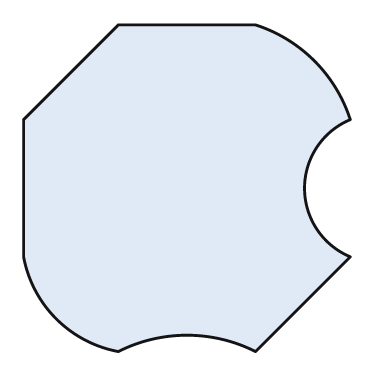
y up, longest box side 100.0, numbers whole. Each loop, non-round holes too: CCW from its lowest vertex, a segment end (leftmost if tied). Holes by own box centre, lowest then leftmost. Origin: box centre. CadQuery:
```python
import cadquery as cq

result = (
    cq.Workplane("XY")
    .moveTo(-21.0, -50.0)
    .threePointArc((0.0, -45.0), (21.0, -50.0))
    .lineTo(50.0, -21.0)
    .threePointArc((36.0, 0.0), (50.0, 21.0))
    .threePointArc((39.0, 39.0), (21.0, 50.0))
    .lineTo(-21.0, 50.0)
    .lineTo(-50.0, 21.0)
    .lineTo(-50.0, -21.0)
    .threePointArc((-40.0, -40.0), (-21.0, -50.0))
    .close()
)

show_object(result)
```